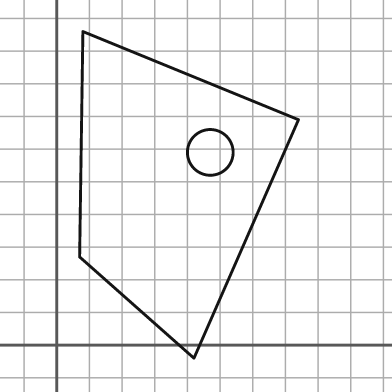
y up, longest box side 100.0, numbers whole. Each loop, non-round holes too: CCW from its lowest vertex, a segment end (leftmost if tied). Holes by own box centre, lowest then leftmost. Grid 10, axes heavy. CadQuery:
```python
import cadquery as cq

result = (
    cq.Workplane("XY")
    .moveTo(42.0, -4.0)
    .lineTo(74.0, 69.0)
    .lineTo(8.0, 96.0)
    .lineTo(7.0, 27.0)
    .close()
    .moveTo(47.0, 59.0)
    .circle(7.0)
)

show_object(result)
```